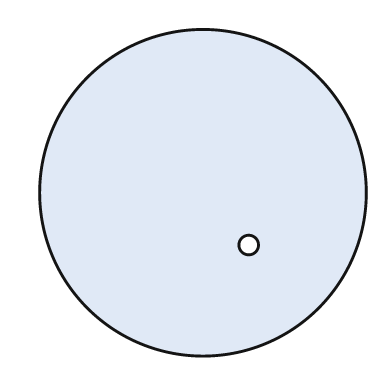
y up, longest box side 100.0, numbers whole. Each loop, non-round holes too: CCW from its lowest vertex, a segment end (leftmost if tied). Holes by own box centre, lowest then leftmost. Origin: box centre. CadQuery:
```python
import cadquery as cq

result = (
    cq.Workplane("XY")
    .moveTo(0.0, 0.0)
    .circle(50.0)
    .moveTo(14.0, -16.0)
    .circle(3.0)
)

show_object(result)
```